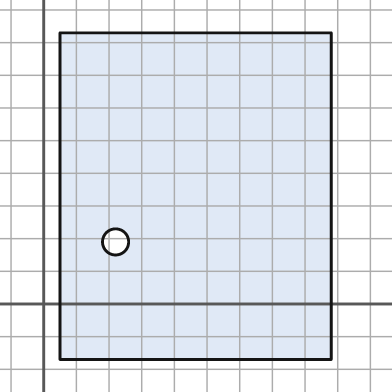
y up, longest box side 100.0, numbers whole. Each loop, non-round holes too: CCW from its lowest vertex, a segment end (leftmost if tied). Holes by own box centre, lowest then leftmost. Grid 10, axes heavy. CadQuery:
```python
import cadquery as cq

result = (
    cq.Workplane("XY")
    .moveTo(5.0, -17.0)
    .lineTo(88.0, -17.0)
    .lineTo(88.0, 83.0)
    .lineTo(5.0, 83.0)
    .close()
    .moveTo(22.0, 19.0)
    .circle(4.0)
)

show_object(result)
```